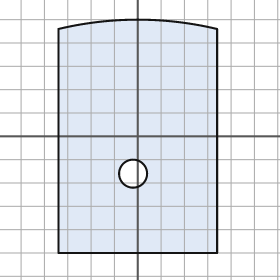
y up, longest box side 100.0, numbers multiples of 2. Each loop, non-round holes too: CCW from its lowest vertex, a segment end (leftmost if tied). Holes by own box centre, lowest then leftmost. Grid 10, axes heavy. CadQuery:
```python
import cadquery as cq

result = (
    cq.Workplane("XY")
    .moveTo(-34.0, -50.0)
    .lineTo(34.0, -50.0)
    .lineTo(34.0, 46.0)
    .threePointArc((0.0, 50.0), (-34.0, 46.0))
    .close()
    .moveTo(-2.0, -16.0)
    .circle(6.0)
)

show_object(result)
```